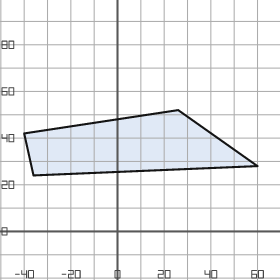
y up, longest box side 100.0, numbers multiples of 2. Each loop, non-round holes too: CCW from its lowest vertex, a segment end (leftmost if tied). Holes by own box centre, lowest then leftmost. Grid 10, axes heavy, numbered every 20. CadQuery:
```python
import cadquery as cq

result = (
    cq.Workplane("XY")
    .moveTo(-36.0, 24.0)
    .lineTo(60.0, 28.0)
    .lineTo(26.0, 52.0)
    .lineTo(-40.0, 42.0)
    .close()
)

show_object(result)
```